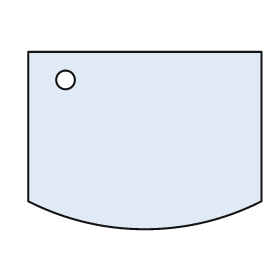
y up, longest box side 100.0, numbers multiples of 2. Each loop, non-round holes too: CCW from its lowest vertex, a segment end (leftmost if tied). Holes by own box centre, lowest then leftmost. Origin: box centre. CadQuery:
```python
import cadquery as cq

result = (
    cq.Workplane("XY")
    .moveTo(-50.0, -26.0)
    .threePointArc((0.0, -38.0), (50.0, -26.0))
    .lineTo(50.0, 38.0)
    .lineTo(-50.0, 38.0)
    .close()
    .moveTo(-34.0, 26.0)
    .circle(4.0)
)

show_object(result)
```